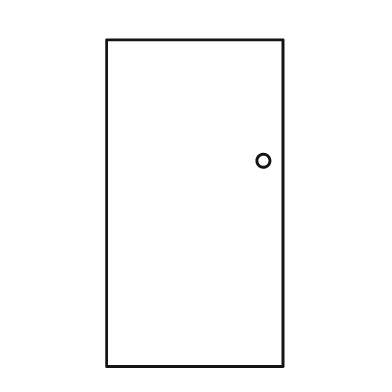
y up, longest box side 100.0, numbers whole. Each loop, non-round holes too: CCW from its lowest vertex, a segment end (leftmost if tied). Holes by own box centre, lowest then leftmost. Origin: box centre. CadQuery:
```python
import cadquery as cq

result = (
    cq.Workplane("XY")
    .moveTo(-27.0, -50.0)
    .lineTo(27.0, -50.0)
    .lineTo(27.0, 50.0)
    .lineTo(-27.0, 50.0)
    .close()
    .moveTo(21.0, 13.0)
    .circle(2.0)
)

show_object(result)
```